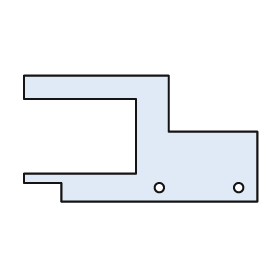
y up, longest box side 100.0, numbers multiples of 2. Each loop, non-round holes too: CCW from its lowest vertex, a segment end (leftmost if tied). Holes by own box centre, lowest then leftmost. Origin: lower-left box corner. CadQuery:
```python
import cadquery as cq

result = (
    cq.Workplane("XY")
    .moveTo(16.0, 0.0)
    .lineTo(100.0, 0.0)
    .lineTo(100.0, 30.0)
    .lineTo(62.0, 30.0)
    .lineTo(62.0, 54.0)
    .lineTo(0.0, 54.0)
    .lineTo(0.0, 44.0)
    .lineTo(48.0, 44.0)
    .lineTo(48.0, 12.0)
    .lineTo(0.0, 12.0)
    .lineTo(0.0, 8.0)
    .lineTo(16.0, 8.0)
    .close()
    .moveTo(58.0, 6.0)
    .circle(2.0)
    .moveTo(92.0, 6.0)
    .circle(2.0)
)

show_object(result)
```